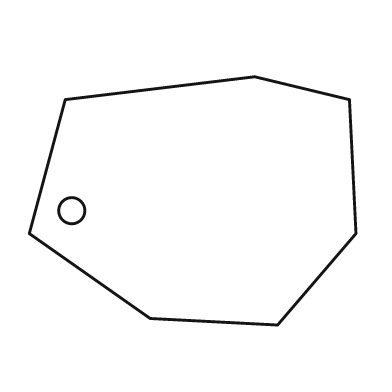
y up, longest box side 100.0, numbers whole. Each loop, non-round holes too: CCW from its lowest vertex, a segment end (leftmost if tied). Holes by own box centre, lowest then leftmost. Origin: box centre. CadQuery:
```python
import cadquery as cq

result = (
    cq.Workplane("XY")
    .moveTo(26.0, -38.0)
    .lineTo(50.0, -10.0)
    .lineTo(48.0, 31.0)
    .lineTo(19.0, 38.0)
    .lineTo(-39.0, 31.0)
    .lineTo(-50.0, -10.0)
    .lineTo(-13.0, -36.0)
    .close()
    .moveTo(-37.0, -3.0)
    .circle(4.0)
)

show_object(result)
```